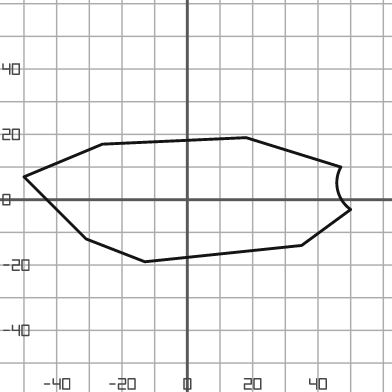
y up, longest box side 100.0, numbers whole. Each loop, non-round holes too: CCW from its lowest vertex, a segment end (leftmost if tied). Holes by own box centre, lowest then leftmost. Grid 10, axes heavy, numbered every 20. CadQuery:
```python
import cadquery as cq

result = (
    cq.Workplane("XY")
    .moveTo(-13.0, -19.0)
    .lineTo(35.0, -14.0)
    .lineTo(50.0, -3.0)
    .threePointArc((46.0, 3.0), (47.0, 10.0))
    .lineTo(18.0, 19.0)
    .lineTo(-26.0, 17.0)
    .lineTo(-50.0, 7.0)
    .lineTo(-31.0, -12.0)
    .close()
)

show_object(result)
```